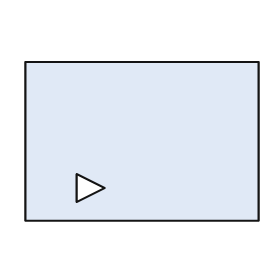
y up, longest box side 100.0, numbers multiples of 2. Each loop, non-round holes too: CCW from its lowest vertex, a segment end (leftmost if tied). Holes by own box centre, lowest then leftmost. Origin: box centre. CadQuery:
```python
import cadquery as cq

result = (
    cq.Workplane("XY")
    .moveTo(-50.0, -34.0)
    .lineTo(50.0, -34.0)
    .lineTo(50.0, 34.0)
    .lineTo(-50.0, 34.0)
    .close()
    .moveTo(-28.0, -26.0)
    .lineTo(-16.0, -20.0)
    .lineTo(-28.0, -14.0)
    .close()
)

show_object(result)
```